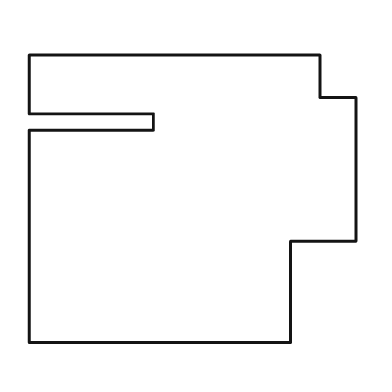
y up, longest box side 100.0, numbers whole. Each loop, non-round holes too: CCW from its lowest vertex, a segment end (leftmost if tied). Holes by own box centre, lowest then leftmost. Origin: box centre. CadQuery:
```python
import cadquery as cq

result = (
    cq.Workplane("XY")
    .moveTo(-50.0, -44.0)
    .lineTo(30.0, -44.0)
    .lineTo(30.0, -13.0)
    .lineTo(50.0, -13.0)
    .lineTo(50.0, 31.0)
    .lineTo(39.0, 31.0)
    .lineTo(39.0, 44.0)
    .lineTo(-50.0, 44.0)
    .lineTo(-50.0, 26.0)
    .lineTo(-12.0, 26.0)
    .lineTo(-12.0, 21.0)
    .lineTo(-50.0, 21.0)
    .close()
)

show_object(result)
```